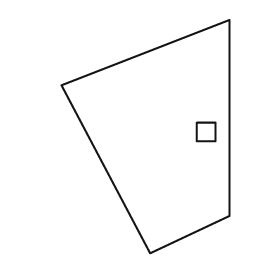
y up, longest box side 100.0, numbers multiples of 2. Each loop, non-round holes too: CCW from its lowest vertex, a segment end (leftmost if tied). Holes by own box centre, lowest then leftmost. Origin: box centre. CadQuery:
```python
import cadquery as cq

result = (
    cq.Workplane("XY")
    .moveTo(2.0, -50.0)
    .lineTo(36.0, -34.0)
    .lineTo(36.0, 50.0)
    .lineTo(-36.0, 22.0)
    .close()
    .moveTo(22.0, -2.0)
    .lineTo(30.0, -2.0)
    .lineTo(30.0, 6.0)
    .lineTo(22.0, 6.0)
    .close()
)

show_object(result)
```